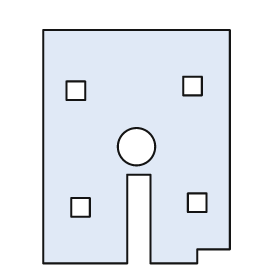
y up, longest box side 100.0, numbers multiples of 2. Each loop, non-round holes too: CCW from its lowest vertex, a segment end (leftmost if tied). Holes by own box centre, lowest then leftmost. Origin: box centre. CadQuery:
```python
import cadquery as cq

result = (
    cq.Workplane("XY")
    .moveTo(-40.0, -50.0)
    .lineTo(-4.0, -50.0)
    .lineTo(-4.0, -12.0)
    .lineTo(6.0, -12.0)
    .lineTo(6.0, -50.0)
    .lineTo(26.0, -50.0)
    .lineTo(26.0, -44.0)
    .lineTo(40.0, -44.0)
    .lineTo(40.0, 50.0)
    .lineTo(-40.0, 50.0)
    .close()
    .moveTo(-28.0, -30.0)
    .lineTo(-20.0, -30.0)
    .lineTo(-20.0, -22.0)
    .lineTo(-28.0, -22.0)
    .close()
    .moveTo(22.0, -28.0)
    .lineTo(30.0, -28.0)
    .lineTo(30.0, -20.0)
    .lineTo(22.0, -20.0)
    .close()
    .moveTo(0.0, 0.0)
    .circle(8.0)
    .moveTo(-30.0, 20.0)
    .lineTo(-22.0, 20.0)
    .lineTo(-22.0, 28.0)
    .lineTo(-30.0, 28.0)
    .close()
    .moveTo(20.0, 22.0)
    .lineTo(28.0, 22.0)
    .lineTo(28.0, 30.0)
    .lineTo(20.0, 30.0)
    .close()
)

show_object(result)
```